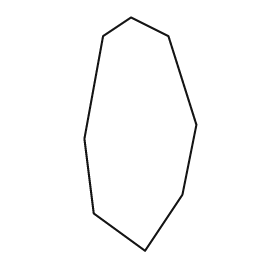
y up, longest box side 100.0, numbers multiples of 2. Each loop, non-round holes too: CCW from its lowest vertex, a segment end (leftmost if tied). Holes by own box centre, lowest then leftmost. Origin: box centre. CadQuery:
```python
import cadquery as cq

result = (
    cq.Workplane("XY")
    .moveTo(2.0, -50.0)
    .lineTo(18.0, -26.0)
    .lineTo(24.0, 4.0)
    .lineTo(12.0, 42.0)
    .lineTo(-4.0, 50.0)
    .lineTo(-16.0, 42.0)
    .lineTo(-24.0, -2.0)
    .lineTo(-20.0, -34.0)
    .close()
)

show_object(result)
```